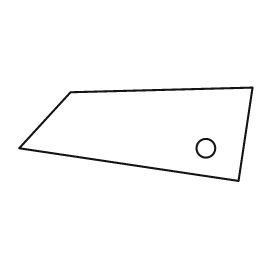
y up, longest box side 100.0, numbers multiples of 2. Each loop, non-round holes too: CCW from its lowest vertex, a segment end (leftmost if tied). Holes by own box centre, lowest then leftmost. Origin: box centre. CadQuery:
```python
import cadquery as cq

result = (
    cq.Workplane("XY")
    .moveTo(44.0, -20.0)
    .lineTo(50.0, 20.0)
    .lineTo(-28.0, 18.0)
    .lineTo(-50.0, -6.0)
    .close()
    .moveTo(30.0, -6.0)
    .circle(4.0)
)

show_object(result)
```